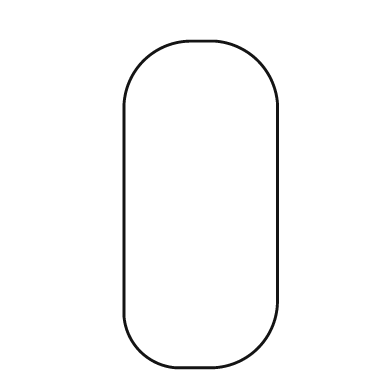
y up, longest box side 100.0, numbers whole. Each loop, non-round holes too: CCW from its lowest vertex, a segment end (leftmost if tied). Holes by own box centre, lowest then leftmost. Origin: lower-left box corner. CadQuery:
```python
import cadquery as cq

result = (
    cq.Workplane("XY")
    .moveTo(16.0, 0.0)
    .lineTo(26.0, 0.0)
    .threePointArc((41.0, 6.0), (47.0, 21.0))
    .lineTo(47.0, 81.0)
    .threePointArc((41.0, 94.0), (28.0, 100.0))
    .lineTo(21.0, 100.0)
    .threePointArc((6.0, 94.0), (0.0, 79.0))
    .lineTo(0.0, 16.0)
    .threePointArc((5.0, 5.0), (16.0, 0.0))
    .close()
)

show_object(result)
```